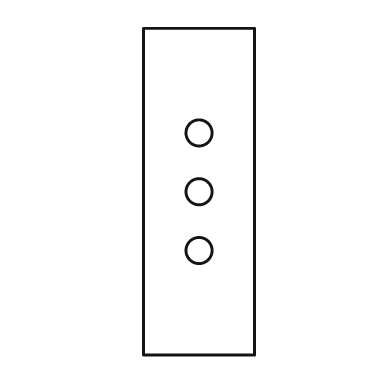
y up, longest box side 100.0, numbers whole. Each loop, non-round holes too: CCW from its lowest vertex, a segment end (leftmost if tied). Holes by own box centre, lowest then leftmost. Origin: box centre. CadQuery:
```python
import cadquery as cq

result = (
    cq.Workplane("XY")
    .moveTo(-17.0, -50.0)
    .lineTo(17.0, -50.0)
    .lineTo(17.0, 50.0)
    .lineTo(-17.0, 50.0)
    .close()
    .moveTo(0.0, -18.0)
    .circle(4.0)
    .moveTo(0.0, 0.0)
    .circle(4.0)
    .moveTo(0.0, 18.0)
    .circle(4.0)
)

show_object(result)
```